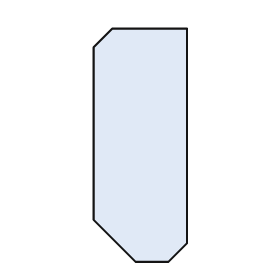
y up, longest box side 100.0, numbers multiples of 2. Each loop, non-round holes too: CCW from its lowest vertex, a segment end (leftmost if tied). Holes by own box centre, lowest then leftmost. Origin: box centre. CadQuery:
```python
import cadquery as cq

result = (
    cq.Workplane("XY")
    .moveTo(-2.0, -50.0)
    .lineTo(12.0, -50.0)
    .lineTo(20.0, -42.0)
    .lineTo(20.0, 50.0)
    .lineTo(-12.0, 50.0)
    .lineTo(-20.0, 42.0)
    .lineTo(-20.0, -32.0)
    .close()
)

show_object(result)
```